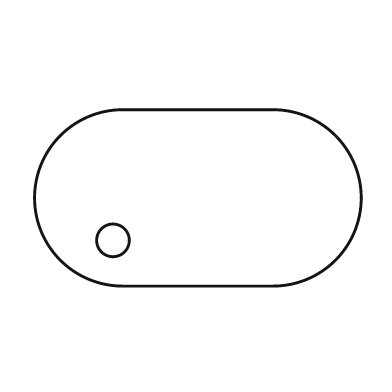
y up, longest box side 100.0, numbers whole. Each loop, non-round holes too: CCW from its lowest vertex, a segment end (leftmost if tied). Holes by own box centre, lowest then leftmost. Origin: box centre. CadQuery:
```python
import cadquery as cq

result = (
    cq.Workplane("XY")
    .moveTo(-23.0, -27.0)
    .lineTo(23.0, -27.0)
    .threePointArc((50.0, 0.0), (23.0, 27.0))
    .lineTo(-23.0, 27.0)
    .threePointArc((-50.0, 0.0), (-23.0, -27.0))
    .close()
    .moveTo(-26.0, -13.0)
    .circle(5.0)
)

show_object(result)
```